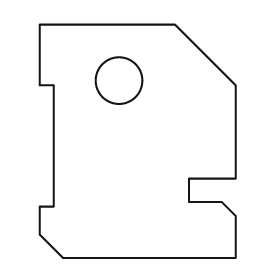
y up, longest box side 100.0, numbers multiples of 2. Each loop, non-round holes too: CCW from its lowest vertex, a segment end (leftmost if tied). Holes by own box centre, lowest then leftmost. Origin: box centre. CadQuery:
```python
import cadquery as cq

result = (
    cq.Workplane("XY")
    .moveTo(-32.0, -50.0)
    .lineTo(42.0, -50.0)
    .lineTo(42.0, -32.0)
    .lineTo(36.0, -26.0)
    .lineTo(22.0, -26.0)
    .lineTo(22.0, -16.0)
    .lineTo(42.0, -16.0)
    .lineTo(42.0, 24.0)
    .lineTo(16.0, 50.0)
    .lineTo(-42.0, 50.0)
    .lineTo(-42.0, 24.0)
    .lineTo(-36.0, 24.0)
    .lineTo(-36.0, -28.0)
    .lineTo(-42.0, -28.0)
    .lineTo(-42.0, -40.0)
    .close()
    .moveTo(-8.0, 26.0)
    .circle(10.0)
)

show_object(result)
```